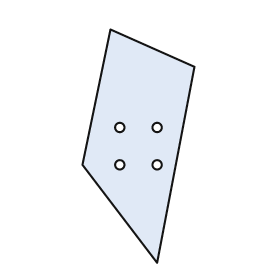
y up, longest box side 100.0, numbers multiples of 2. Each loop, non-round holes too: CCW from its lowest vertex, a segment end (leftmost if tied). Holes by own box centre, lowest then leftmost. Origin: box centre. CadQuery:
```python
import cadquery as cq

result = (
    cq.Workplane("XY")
    .moveTo(8.0, -50.0)
    .lineTo(24.0, 34.0)
    .lineTo(-12.0, 50.0)
    .lineTo(-24.0, -8.0)
    .close()
    .moveTo(-8.0, -8.0)
    .circle(2.0)
    .moveTo(8.0, -8.0)
    .circle(2.0)
    .moveTo(-8.0, 8.0)
    .circle(2.0)
    .moveTo(8.0, 8.0)
    .circle(2.0)
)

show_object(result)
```